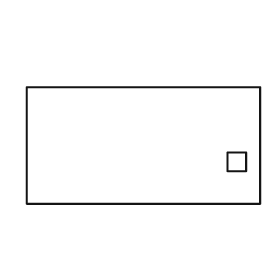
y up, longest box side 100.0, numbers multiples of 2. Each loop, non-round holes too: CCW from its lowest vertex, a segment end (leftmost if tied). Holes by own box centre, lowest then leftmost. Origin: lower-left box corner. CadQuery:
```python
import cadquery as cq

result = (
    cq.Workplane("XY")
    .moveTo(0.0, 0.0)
    .lineTo(100.0, 0.0)
    .lineTo(100.0, 50.0)
    .lineTo(0.0, 50.0)
    .close()
    .moveTo(86.0, 14.0)
    .lineTo(94.0, 14.0)
    .lineTo(94.0, 22.0)
    .lineTo(86.0, 22.0)
    .close()
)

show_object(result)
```